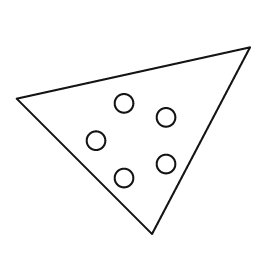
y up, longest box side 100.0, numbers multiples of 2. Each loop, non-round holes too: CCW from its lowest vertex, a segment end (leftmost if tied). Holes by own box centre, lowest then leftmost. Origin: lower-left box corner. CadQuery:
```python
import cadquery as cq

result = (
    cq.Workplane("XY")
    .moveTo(58.0, 0.0)
    .lineTo(100.0, 80.0)
    .lineTo(0.0, 58.0)
    .close()
    .moveTo(46.0, 24.0)
    .circle(4.0)
    .moveTo(64.0, 30.0)
    .circle(4.0)
    .moveTo(34.0, 40.0)
    .circle(4.0)
    .moveTo(64.0, 50.0)
    .circle(4.0)
    .moveTo(46.0, 56.0)
    .circle(4.0)
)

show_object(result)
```